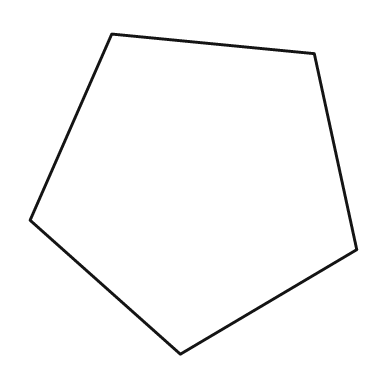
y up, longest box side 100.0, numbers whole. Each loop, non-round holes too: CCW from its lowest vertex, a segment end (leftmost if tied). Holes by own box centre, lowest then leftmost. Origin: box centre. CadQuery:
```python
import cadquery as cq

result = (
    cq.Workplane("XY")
    .moveTo(-4.0, -49.0)
    .lineTo(50.0, -17.0)
    .lineTo(37.0, 43.0)
    .lineTo(-25.0, 49.0)
    .lineTo(-50.0, -8.0)
    .close()
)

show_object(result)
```